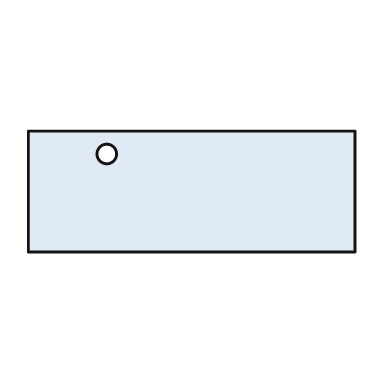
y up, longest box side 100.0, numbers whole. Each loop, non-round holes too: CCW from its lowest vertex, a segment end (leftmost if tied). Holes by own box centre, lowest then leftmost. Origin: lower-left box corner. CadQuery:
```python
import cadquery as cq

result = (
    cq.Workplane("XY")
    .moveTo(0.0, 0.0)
    .lineTo(100.0, 0.0)
    .lineTo(100.0, 37.0)
    .lineTo(0.0, 37.0)
    .close()
    .moveTo(24.0, 30.0)
    .circle(3.0)
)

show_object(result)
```